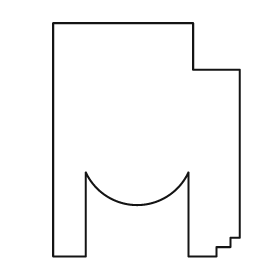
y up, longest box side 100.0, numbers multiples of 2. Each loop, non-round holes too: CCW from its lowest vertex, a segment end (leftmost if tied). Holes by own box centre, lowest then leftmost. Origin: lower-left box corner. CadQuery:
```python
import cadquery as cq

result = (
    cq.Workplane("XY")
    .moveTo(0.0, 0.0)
    .lineTo(14.0, 0.0)
    .lineTo(14.0, 36.0)
    .threePointArc((36.0, 22.0), (58.0, 36.0))
    .lineTo(58.0, 0.0)
    .lineTo(70.0, 0.0)
    .lineTo(70.0, 4.0)
    .lineTo(76.0, 4.0)
    .lineTo(76.0, 8.0)
    .lineTo(80.0, 8.0)
    .lineTo(80.0, 80.0)
    .lineTo(60.0, 80.0)
    .lineTo(60.0, 100.0)
    .lineTo(0.0, 100.0)
    .close()
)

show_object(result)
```